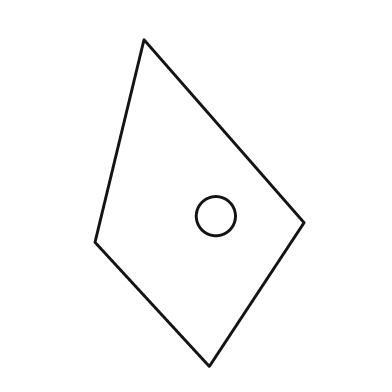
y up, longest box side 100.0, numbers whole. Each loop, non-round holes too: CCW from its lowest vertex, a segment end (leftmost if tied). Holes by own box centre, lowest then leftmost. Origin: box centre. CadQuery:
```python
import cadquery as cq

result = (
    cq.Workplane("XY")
    .moveTo(3.0, -50.0)
    .lineTo(32.0, -6.0)
    .lineTo(-17.0, 50.0)
    .lineTo(-32.0, -12.0)
    .close()
    .moveTo(5.0, -4.0)
    .circle(6.0)
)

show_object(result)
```